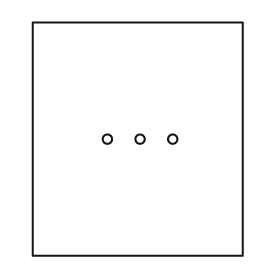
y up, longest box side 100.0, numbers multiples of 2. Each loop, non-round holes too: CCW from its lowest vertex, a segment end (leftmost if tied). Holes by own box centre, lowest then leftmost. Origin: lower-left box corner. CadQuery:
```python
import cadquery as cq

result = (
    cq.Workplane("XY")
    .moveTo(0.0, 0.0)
    .lineTo(90.0, 0.0)
    .lineTo(90.0, 100.0)
    .lineTo(0.0, 100.0)
    .close()
    .moveTo(32.0, 50.0)
    .circle(2.0)
    .moveTo(46.0, 50.0)
    .circle(2.0)
    .moveTo(60.0, 50.0)
    .circle(2.0)
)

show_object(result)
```